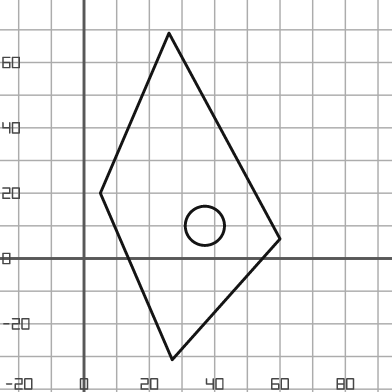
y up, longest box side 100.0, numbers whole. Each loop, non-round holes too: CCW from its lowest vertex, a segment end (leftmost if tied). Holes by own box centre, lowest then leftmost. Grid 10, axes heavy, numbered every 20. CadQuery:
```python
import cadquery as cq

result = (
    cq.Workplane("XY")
    .moveTo(27.0, -31.0)
    .lineTo(60.0, 6.0)
    .lineTo(26.0, 69.0)
    .lineTo(5.0, 20.0)
    .close()
    .moveTo(37.0, 10.0)
    .circle(6.0)
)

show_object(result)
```